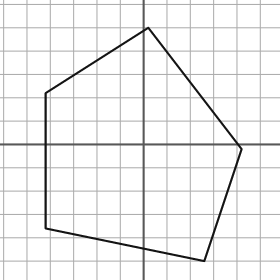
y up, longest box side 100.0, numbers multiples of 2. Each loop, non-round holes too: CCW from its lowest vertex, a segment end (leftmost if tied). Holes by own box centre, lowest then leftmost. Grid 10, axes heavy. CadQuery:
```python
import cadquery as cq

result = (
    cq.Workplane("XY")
    .moveTo(26.0, -50.0)
    .lineTo(42.0, -2.0)
    .lineTo(2.0, 50.0)
    .lineTo(-42.0, 22.0)
    .lineTo(-42.0, -36.0)
    .close()
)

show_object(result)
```